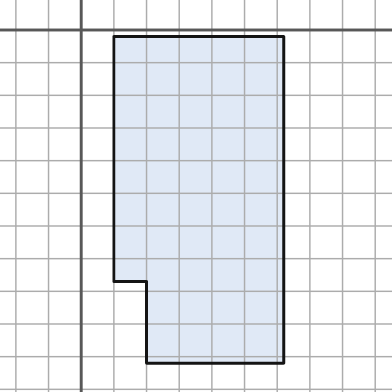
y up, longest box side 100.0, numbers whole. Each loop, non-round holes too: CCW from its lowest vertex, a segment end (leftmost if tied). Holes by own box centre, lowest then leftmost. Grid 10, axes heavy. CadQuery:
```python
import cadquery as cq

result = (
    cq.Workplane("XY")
    .moveTo(20.0, -102.0)
    .lineTo(62.0, -102.0)
    .lineTo(62.0, -2.0)
    .lineTo(10.0, -2.0)
    .lineTo(10.0, -77.0)
    .lineTo(20.0, -77.0)
    .close()
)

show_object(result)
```